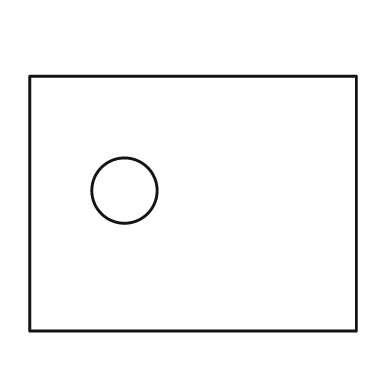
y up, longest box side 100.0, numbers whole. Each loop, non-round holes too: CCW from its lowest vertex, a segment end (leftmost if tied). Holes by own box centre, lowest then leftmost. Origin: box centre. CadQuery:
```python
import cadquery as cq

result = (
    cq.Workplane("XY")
    .moveTo(-50.0, -39.0)
    .lineTo(50.0, -39.0)
    .lineTo(50.0, 39.0)
    .lineTo(-50.0, 39.0)
    .close()
    .moveTo(-21.0, 4.0)
    .circle(10.0)
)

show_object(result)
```